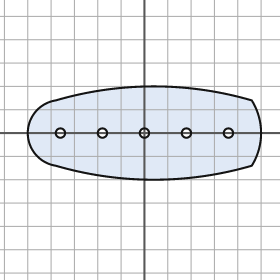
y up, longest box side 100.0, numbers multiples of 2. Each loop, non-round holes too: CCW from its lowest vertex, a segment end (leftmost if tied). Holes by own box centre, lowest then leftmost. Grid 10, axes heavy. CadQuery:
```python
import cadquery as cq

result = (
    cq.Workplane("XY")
    .moveTo(-38.0, -14.0)
    .threePointArc((4.0, -20.0), (46.0, -14.0))
    .threePointArc((50.0, 0.0), (46.0, 14.0))
    .threePointArc((4.0, 20.0), (-38.0, 14.0))
    .threePointArc((-50.0, 0.0), (-38.0, -14.0))
    .close()
    .moveTo(-36.0, 0.0)
    .circle(2.0)
    .moveTo(-18.0, 0.0)
    .circle(2.0)
    .moveTo(0.0, 0.0)
    .circle(2.0)
    .moveTo(18.0, 0.0)
    .circle(2.0)
    .moveTo(36.0, 0.0)
    .circle(2.0)
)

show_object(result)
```